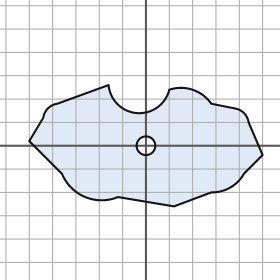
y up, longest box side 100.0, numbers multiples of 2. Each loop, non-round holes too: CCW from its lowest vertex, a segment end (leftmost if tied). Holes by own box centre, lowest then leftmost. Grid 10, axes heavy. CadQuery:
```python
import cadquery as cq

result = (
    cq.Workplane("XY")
    .moveTo(12.0, -26.0)
    .lineTo(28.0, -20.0)
    .threePointArc((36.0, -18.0), (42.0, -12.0))
    .lineTo(50.0, -4.0)
    .lineTo(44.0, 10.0)
    .threePointArc((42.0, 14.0), (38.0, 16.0))
    .lineTo(28.0, 18.0)
    .threePointArc((20.0, 24.0), (10.0, 24.0))
    .threePointArc((-4.0, 14.0), (-16.0, 26.0))
    .lineTo(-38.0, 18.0)
    .threePointArc((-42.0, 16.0), (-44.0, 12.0))
    .lineTo(-50.0, 2.0)
    .lineTo(-36.0, -12.0)
    .threePointArc((-26.0, -22.0), (-12.0, -22.0))
    .close()
    .moveTo(0.0, 0.0)
    .circle(4.0)
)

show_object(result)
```